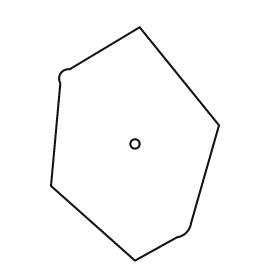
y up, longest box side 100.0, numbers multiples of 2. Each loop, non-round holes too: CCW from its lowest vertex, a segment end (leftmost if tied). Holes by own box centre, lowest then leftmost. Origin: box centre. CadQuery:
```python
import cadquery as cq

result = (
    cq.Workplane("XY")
    .moveTo(0.0, -50.0)
    .lineTo(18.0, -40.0)
    .threePointArc((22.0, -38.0), (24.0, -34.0))
    .lineTo(36.0, 8.0)
    .lineTo(2.0, 50.0)
    .lineTo(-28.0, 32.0)
    .threePointArc((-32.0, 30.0), (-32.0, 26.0))
    .lineTo(-36.0, -18.0)
    .close()
    .moveTo(0.0, 0.0)
    .circle(2.0)
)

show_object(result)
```